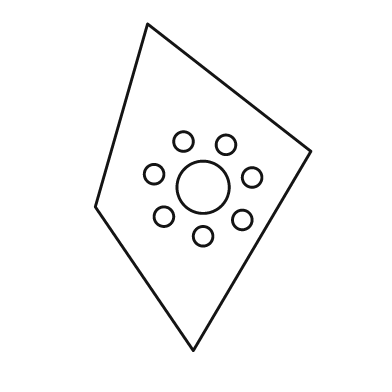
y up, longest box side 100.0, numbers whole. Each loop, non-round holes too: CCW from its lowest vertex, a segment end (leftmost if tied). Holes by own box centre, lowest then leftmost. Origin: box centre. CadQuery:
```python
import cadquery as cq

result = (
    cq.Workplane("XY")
    .moveTo(-3.0, -50.0)
    .lineTo(33.0, 11.0)
    .lineTo(-17.0, 50.0)
    .lineTo(-33.0, -6.0)
    .close()
    .moveTo(0.0, -15.0)
    .circle(3.0)
    .moveTo(12.0, -10.0)
    .circle(3.0)
    .moveTo(-12.0, -9.0)
    .circle(3.0)
    .moveTo(0.0, 0.0)
    .circle(8.0)
    .moveTo(15.0, 3.0)
    .circle(3.0)
    .moveTo(-15.0, 4.0)
    .circle(3.0)
    .moveTo(7.0, 13.0)
    .circle(3.0)
    .moveTo(-6.0, 14.0)
    .circle(3.0)
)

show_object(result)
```